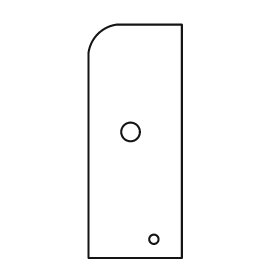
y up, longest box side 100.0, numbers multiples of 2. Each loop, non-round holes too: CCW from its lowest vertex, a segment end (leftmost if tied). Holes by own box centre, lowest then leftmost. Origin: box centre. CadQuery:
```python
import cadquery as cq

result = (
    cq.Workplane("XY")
    .moveTo(-20.0, -50.0)
    .lineTo(20.0, -50.0)
    .lineTo(20.0, 50.0)
    .lineTo(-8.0, 50.0)
    .threePointArc((-16.0, 46.0), (-20.0, 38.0))
    .close()
    .moveTo(8.0, -42.0)
    .circle(2.0)
    .moveTo(-2.0, 4.0)
    .circle(4.0)
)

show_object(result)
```